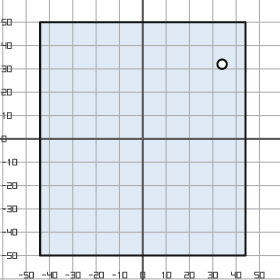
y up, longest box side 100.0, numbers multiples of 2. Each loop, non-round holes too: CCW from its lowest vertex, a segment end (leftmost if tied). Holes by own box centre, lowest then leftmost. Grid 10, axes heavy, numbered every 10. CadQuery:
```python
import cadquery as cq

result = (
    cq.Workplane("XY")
    .moveTo(-44.0, -50.0)
    .lineTo(44.0, -50.0)
    .lineTo(44.0, 50.0)
    .lineTo(-44.0, 50.0)
    .close()
    .moveTo(34.0, 32.0)
    .circle(2.0)
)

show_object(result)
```